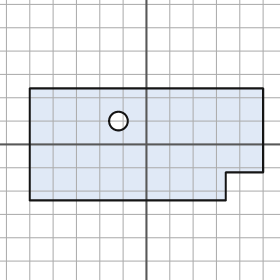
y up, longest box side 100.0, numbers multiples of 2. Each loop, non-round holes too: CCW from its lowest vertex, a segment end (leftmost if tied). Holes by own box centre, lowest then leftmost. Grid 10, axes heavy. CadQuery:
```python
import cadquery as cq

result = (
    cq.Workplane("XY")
    .moveTo(-50.0, -24.0)
    .lineTo(34.0, -24.0)
    .lineTo(34.0, -12.0)
    .lineTo(50.0, -12.0)
    .lineTo(50.0, 24.0)
    .lineTo(-50.0, 24.0)
    .close()
    .moveTo(-12.0, 10.0)
    .circle(4.0)
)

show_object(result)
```